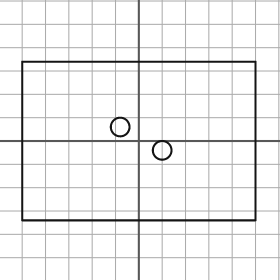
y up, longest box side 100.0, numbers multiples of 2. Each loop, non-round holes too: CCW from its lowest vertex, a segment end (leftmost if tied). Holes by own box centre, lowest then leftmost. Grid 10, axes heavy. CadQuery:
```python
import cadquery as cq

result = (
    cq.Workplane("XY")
    .moveTo(-50.0, -34.0)
    .lineTo(50.0, -34.0)
    .lineTo(50.0, 34.0)
    .lineTo(-50.0, 34.0)
    .close()
    .moveTo(10.0, -4.0)
    .circle(4.0)
    .moveTo(-8.0, 6.0)
    .circle(4.0)
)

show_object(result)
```